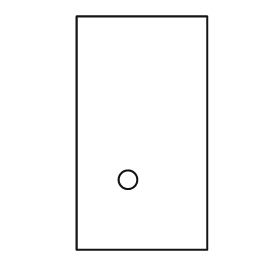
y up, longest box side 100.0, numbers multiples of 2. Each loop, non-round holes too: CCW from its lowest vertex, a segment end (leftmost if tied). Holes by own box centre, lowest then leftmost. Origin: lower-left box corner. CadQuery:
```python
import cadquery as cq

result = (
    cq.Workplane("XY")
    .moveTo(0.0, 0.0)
    .lineTo(56.0, 0.0)
    .lineTo(56.0, 100.0)
    .lineTo(0.0, 100.0)
    .close()
    .moveTo(22.0, 30.0)
    .circle(4.0)
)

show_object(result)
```